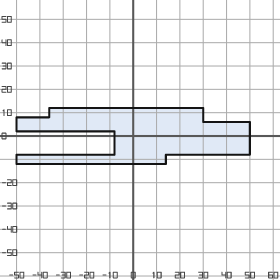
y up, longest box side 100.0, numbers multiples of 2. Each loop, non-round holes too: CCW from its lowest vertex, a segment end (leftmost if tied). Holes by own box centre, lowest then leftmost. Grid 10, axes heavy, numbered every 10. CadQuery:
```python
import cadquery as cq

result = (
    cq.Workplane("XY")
    .moveTo(-50.0, -12.0)
    .lineTo(14.0, -12.0)
    .lineTo(14.0, -8.0)
    .lineTo(50.0, -8.0)
    .lineTo(50.0, 6.0)
    .lineTo(30.0, 6.0)
    .lineTo(30.0, 12.0)
    .lineTo(-36.0, 12.0)
    .lineTo(-36.0, 8.0)
    .lineTo(-50.0, 8.0)
    .lineTo(-50.0, 2.0)
    .lineTo(-8.0, 2.0)
    .lineTo(-8.0, -8.0)
    .lineTo(-50.0, -8.0)
    .close()
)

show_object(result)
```